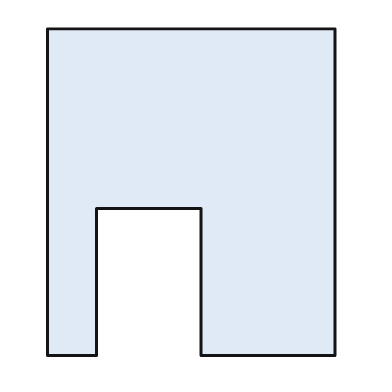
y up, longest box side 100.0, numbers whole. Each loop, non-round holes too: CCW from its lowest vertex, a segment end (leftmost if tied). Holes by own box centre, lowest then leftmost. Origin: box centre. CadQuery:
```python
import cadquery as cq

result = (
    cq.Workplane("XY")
    .moveTo(-44.0, -50.0)
    .lineTo(-29.0, -50.0)
    .lineTo(-29.0, -5.0)
    .lineTo(3.0, -5.0)
    .lineTo(3.0, -50.0)
    .lineTo(44.0, -50.0)
    .lineTo(44.0, 50.0)
    .lineTo(-44.0, 50.0)
    .close()
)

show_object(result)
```